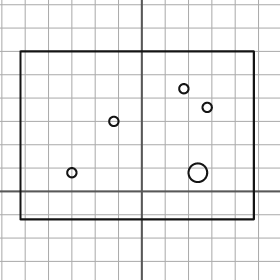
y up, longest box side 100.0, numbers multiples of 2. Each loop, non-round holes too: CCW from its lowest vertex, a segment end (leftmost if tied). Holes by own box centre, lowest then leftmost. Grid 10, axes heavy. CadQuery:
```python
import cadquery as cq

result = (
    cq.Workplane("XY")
    .moveTo(-52.0, -12.0)
    .lineTo(48.0, -12.0)
    .lineTo(48.0, 60.0)
    .lineTo(-52.0, 60.0)
    .close()
    .moveTo(-30.0, 8.0)
    .circle(2.0)
    .moveTo(24.0, 8.0)
    .circle(4.0)
    .moveTo(-12.0, 30.0)
    .circle(2.0)
    .moveTo(28.0, 36.0)
    .circle(2.0)
    .moveTo(18.0, 44.0)
    .circle(2.0)
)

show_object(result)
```